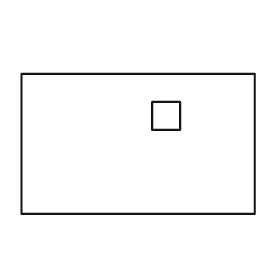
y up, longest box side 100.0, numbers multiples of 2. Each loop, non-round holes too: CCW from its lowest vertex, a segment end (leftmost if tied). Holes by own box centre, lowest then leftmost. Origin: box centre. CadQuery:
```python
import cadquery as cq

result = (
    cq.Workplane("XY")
    .moveTo(-50.0, -30.0)
    .lineTo(50.0, -30.0)
    .lineTo(50.0, 30.0)
    .lineTo(-50.0, 30.0)
    .close()
    .moveTo(6.0, 6.0)
    .lineTo(18.0, 6.0)
    .lineTo(18.0, 18.0)
    .lineTo(6.0, 18.0)
    .close()
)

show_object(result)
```